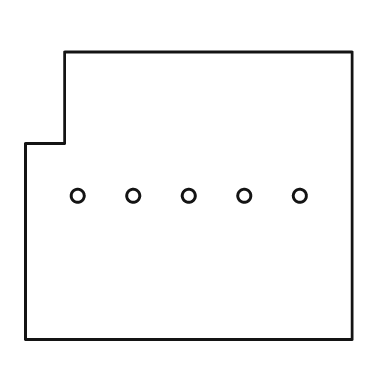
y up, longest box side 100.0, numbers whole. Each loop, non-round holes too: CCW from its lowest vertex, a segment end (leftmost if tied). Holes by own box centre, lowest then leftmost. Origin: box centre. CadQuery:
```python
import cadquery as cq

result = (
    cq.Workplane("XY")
    .moveTo(-50.0, -44.0)
    .lineTo(50.0, -44.0)
    .lineTo(50.0, 44.0)
    .lineTo(-38.0, 44.0)
    .lineTo(-38.0, 16.0)
    .lineTo(-50.0, 16.0)
    .close()
    .moveTo(-34.0, 0.0)
    .circle(2.0)
    .moveTo(-17.0, 0.0)
    .circle(2.0)
    .moveTo(0.0, 0.0)
    .circle(2.0)
    .moveTo(17.0, 0.0)
    .circle(2.0)
    .moveTo(34.0, 0.0)
    .circle(2.0)
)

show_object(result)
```